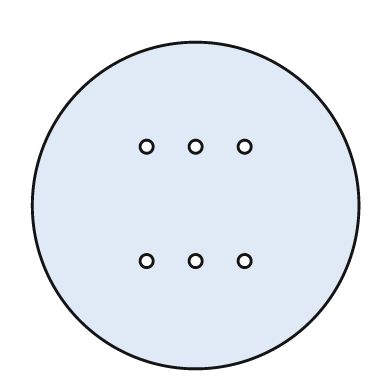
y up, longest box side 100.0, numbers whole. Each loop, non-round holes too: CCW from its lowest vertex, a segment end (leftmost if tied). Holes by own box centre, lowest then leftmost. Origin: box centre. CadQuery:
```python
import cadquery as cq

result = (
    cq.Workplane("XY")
    .moveTo(0.0, 0.0)
    .circle(50.0)
    .moveTo(-15.0, -17.0)
    .circle(2.0)
    .moveTo(0.0, -17.0)
    .circle(2.0)
    .moveTo(15.0, -17.0)
    .circle(2.0)
    .moveTo(-15.0, 18.0)
    .circle(2.0)
    .moveTo(0.0, 18.0)
    .circle(2.0)
    .moveTo(15.0, 18.0)
    .circle(2.0)
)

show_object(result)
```